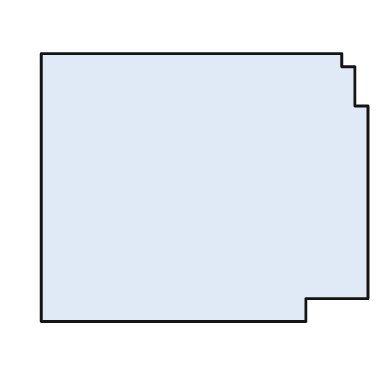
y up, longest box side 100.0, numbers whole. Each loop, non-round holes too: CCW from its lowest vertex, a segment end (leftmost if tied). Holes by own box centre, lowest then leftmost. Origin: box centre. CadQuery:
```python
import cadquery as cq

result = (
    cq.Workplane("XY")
    .moveTo(-50.0, -41.0)
    .lineTo(31.0, -41.0)
    .lineTo(31.0, -34.0)
    .lineTo(50.0, -34.0)
    .lineTo(50.0, 25.0)
    .lineTo(46.0, 25.0)
    .lineTo(46.0, 37.0)
    .lineTo(42.0, 37.0)
    .lineTo(42.0, 41.0)
    .lineTo(-50.0, 41.0)
    .close()
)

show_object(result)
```